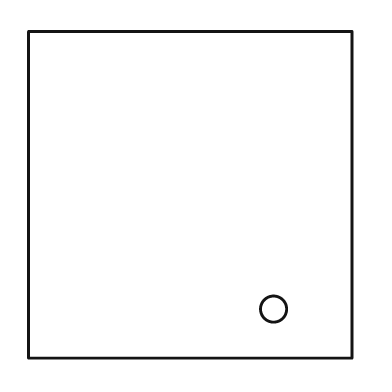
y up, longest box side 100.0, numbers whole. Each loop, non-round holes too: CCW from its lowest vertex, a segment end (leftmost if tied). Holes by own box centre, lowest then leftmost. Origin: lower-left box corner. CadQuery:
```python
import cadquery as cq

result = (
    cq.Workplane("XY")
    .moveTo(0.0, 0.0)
    .lineTo(99.0, 0.0)
    .lineTo(99.0, 100.0)
    .lineTo(0.0, 100.0)
    .close()
    .moveTo(75.0, 15.0)
    .circle(4.0)
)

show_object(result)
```